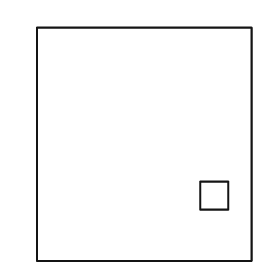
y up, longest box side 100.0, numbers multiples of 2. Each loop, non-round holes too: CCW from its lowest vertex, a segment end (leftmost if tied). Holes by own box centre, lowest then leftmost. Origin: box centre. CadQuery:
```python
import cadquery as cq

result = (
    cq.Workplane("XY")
    .moveTo(-46.0, -50.0)
    .lineTo(46.0, -50.0)
    .lineTo(46.0, 50.0)
    .lineTo(-46.0, 50.0)
    .close()
    .moveTo(24.0, -28.0)
    .lineTo(36.0, -28.0)
    .lineTo(36.0, -16.0)
    .lineTo(24.0, -16.0)
    .close()
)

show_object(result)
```